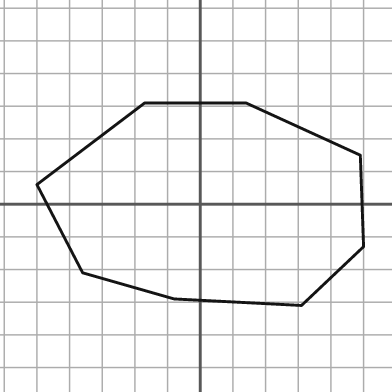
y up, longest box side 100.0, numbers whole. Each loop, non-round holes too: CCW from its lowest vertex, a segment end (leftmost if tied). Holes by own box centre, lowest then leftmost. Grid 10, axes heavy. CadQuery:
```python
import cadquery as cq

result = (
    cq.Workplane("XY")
    .moveTo(31.0, -31.0)
    .lineTo(50.0, -13.0)
    .lineTo(49.0, 15.0)
    .lineTo(14.0, 31.0)
    .lineTo(-17.0, 31.0)
    .lineTo(-50.0, 6.0)
    .lineTo(-36.0, -21.0)
    .lineTo(-8.0, -29.0)
    .close()
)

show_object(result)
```